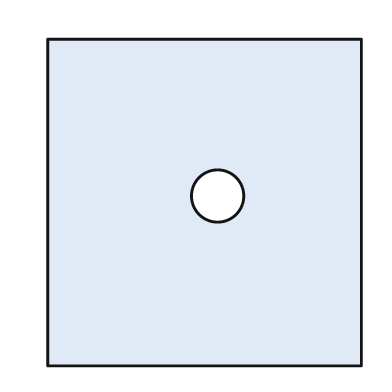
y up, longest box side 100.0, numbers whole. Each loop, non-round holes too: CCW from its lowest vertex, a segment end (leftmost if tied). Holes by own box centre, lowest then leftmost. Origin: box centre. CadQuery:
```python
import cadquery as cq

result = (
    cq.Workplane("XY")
    .moveTo(-48.0, -50.0)
    .lineTo(48.0, -50.0)
    .lineTo(48.0, 50.0)
    .lineTo(-48.0, 50.0)
    .close()
    .moveTo(4.0, 2.0)
    .circle(8.0)
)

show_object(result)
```